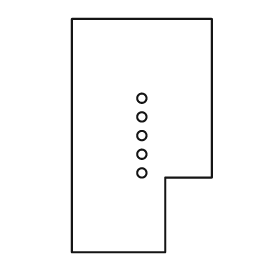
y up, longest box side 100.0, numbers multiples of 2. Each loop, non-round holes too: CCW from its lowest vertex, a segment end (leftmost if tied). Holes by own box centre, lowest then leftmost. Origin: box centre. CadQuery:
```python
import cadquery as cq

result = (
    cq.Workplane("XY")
    .moveTo(-30.0, -50.0)
    .lineTo(10.0, -50.0)
    .lineTo(10.0, -18.0)
    .lineTo(30.0, -18.0)
    .lineTo(30.0, 50.0)
    .lineTo(-30.0, 50.0)
    .close()
    .moveTo(0.0, -16.0)
    .circle(2.0)
    .moveTo(0.0, -8.0)
    .circle(2.0)
    .moveTo(0.0, 0.0)
    .circle(2.0)
    .moveTo(0.0, 8.0)
    .circle(2.0)
    .moveTo(0.0, 16.0)
    .circle(2.0)
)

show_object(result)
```